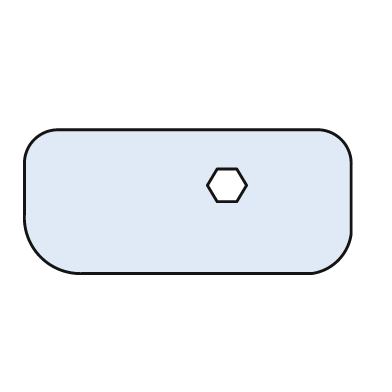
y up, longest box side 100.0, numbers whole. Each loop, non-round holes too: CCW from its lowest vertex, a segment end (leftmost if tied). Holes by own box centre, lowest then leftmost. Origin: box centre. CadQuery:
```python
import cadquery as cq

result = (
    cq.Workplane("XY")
    .moveTo(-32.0, -22.0)
    .lineTo(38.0, -22.0)
    .threePointArc((46.0, -18.0), (50.0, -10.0))
    .lineTo(50.0, 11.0)
    .threePointArc((47.0, 19.0), (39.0, 22.0))
    .lineTo(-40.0, 22.0)
    .threePointArc((-47.0, 19.0), (-50.0, 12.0))
    .lineTo(-50.0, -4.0)
    .threePointArc((-45.0, -17.0), (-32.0, -22.0))
    .close()
    .moveTo(9.0, 0.0)
    .lineTo(15.0, 0.0)
    .lineTo(18.0, 5.0)
    .lineTo(15.0, 10.0)
    .lineTo(9.0, 10.0)
    .lineTo(6.0, 5.0)
    .close()
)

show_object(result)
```